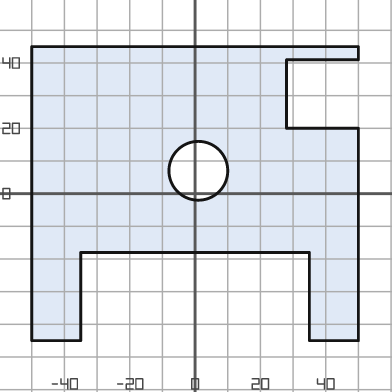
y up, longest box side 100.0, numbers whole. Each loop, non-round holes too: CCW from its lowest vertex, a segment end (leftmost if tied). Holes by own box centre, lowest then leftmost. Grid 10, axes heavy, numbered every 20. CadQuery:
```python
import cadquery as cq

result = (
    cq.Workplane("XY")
    .moveTo(-50.0, -45.0)
    .lineTo(-35.0, -45.0)
    .lineTo(-35.0, -18.0)
    .lineTo(35.0, -18.0)
    .lineTo(35.0, -45.0)
    .lineTo(50.0, -45.0)
    .lineTo(50.0, 20.0)
    .lineTo(28.0, 20.0)
    .lineTo(28.0, 41.0)
    .lineTo(50.0, 41.0)
    .lineTo(50.0, 45.0)
    .lineTo(-50.0, 45.0)
    .close()
    .moveTo(1.0, 7.0)
    .circle(9.0)
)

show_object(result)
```